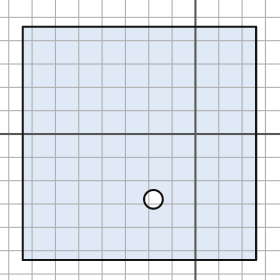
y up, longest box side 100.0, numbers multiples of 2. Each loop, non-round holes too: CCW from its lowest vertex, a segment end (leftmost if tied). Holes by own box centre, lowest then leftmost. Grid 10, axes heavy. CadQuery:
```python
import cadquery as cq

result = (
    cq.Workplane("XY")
    .moveTo(-74.0, -54.0)
    .lineTo(26.0, -54.0)
    .lineTo(26.0, 46.0)
    .lineTo(-74.0, 46.0)
    .close()
    .moveTo(-18.0, -28.0)
    .circle(4.0)
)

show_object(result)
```